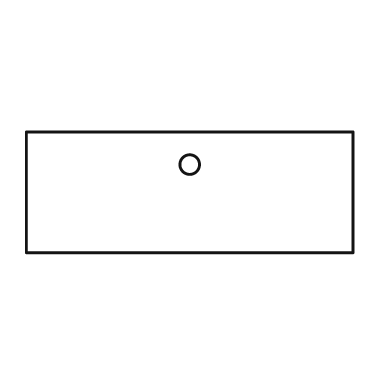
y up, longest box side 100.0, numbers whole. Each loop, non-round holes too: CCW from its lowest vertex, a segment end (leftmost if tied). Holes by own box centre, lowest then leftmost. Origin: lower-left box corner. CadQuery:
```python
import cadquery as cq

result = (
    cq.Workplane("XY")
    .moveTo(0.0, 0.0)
    .lineTo(100.0, 0.0)
    .lineTo(100.0, 37.0)
    .lineTo(0.0, 37.0)
    .close()
    .moveTo(50.0, 27.0)
    .circle(3.0)
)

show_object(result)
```